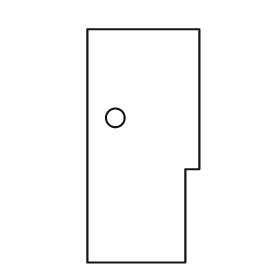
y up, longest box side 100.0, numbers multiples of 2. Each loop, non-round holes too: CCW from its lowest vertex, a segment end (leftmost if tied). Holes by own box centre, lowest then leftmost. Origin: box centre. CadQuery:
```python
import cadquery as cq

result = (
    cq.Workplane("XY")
    .moveTo(-24.0, -50.0)
    .lineTo(18.0, -50.0)
    .lineTo(18.0, -10.0)
    .lineTo(24.0, -10.0)
    .lineTo(24.0, 50.0)
    .lineTo(-24.0, 50.0)
    .close()
    .moveTo(-12.0, 12.0)
    .circle(4.0)
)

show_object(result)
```